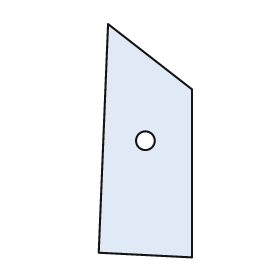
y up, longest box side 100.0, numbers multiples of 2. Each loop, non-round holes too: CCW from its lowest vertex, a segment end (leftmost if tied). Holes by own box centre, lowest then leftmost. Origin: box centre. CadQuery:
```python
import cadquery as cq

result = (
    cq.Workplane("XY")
    .moveTo(20.0, -50.0)
    .lineTo(20.0, 22.0)
    .lineTo(-16.0, 50.0)
    .lineTo(-20.0, -48.0)
    .close()
    .moveTo(0.0, 0.0)
    .circle(4.0)
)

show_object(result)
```